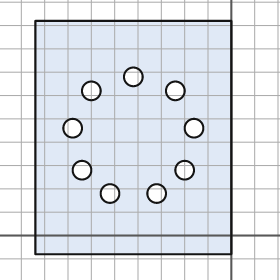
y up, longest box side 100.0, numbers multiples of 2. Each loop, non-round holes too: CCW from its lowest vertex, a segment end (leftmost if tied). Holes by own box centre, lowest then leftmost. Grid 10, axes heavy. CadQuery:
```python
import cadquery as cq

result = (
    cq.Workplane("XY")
    .moveTo(-84.0, -8.0)
    .lineTo(0.0, -8.0)
    .lineTo(0.0, 92.0)
    .lineTo(-84.0, 92.0)
    .close()
    .moveTo(-52.0, 18.0)
    .circle(4.0)
    .moveTo(-32.0, 18.0)
    .circle(4.0)
    .moveTo(-64.0, 28.0)
    .circle(4.0)
    .moveTo(-20.0, 28.0)
    .circle(4.0)
    .moveTo(-68.0, 46.0)
    .circle(4.0)
    .moveTo(-16.0, 46.0)
    .circle(4.0)
    .moveTo(-60.0, 62.0)
    .circle(4.0)
    .moveTo(-24.0, 62.0)
    .circle(4.0)
    .moveTo(-42.0, 68.0)
    .circle(4.0)
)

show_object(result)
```